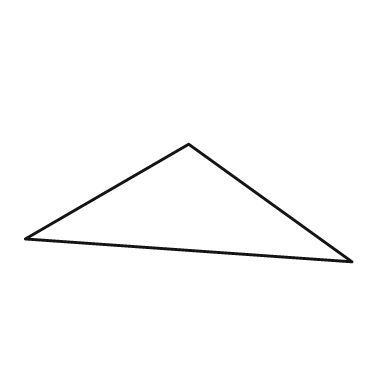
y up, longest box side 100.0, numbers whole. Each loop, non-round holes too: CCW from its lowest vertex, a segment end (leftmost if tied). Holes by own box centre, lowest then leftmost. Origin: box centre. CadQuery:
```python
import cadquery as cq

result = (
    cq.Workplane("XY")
    .moveTo(50.0, -18.0)
    .lineTo(0.0, 18.0)
    .lineTo(-50.0, -11.0)
    .close()
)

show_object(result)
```